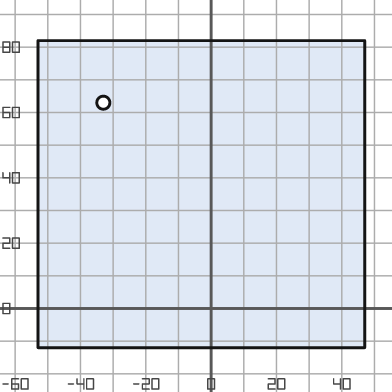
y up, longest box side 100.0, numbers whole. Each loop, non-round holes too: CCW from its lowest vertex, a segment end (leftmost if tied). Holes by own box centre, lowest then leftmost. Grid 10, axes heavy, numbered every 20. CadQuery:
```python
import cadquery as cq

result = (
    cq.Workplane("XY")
    .moveTo(-53.0, -12.0)
    .lineTo(47.0, -12.0)
    .lineTo(47.0, 82.0)
    .lineTo(-53.0, 82.0)
    .close()
    .moveTo(-33.0, 63.0)
    .circle(2.0)
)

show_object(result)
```